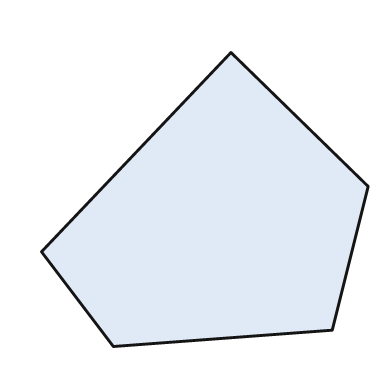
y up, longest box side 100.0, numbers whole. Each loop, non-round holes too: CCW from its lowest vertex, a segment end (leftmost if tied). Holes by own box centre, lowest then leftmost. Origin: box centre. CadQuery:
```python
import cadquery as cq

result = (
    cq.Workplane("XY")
    .moveTo(-28.0, -45.0)
    .lineTo(39.0, -40.0)
    .lineTo(50.0, 4.0)
    .lineTo(8.0, 45.0)
    .lineTo(-50.0, -16.0)
    .close()
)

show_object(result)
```